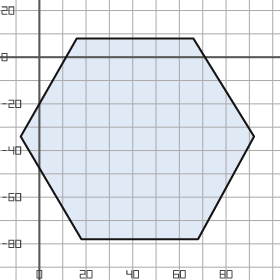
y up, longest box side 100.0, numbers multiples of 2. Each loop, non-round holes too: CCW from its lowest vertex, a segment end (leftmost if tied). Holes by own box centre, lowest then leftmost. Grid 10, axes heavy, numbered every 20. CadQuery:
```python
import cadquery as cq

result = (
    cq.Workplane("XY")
    .moveTo(18.0, -78.0)
    .lineTo(68.0, -78.0)
    .lineTo(92.0, -34.0)
    .lineTo(66.0, 8.0)
    .lineTo(16.0, 8.0)
    .lineTo(-8.0, -34.0)
    .close()
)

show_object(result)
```